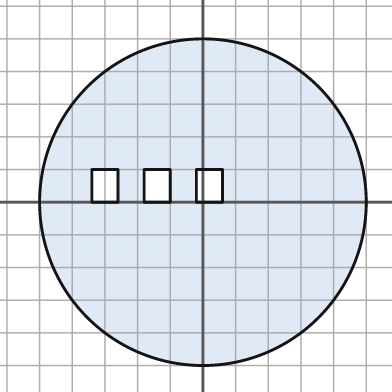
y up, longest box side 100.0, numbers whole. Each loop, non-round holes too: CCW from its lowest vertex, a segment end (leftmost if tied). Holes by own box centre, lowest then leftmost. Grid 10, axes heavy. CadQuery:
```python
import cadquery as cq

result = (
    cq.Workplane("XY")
    .moveTo(0.0, 0.0)
    .circle(50.0)
    .moveTo(-34.0, 0.0)
    .lineTo(-26.0, 0.0)
    .lineTo(-26.0, 10.0)
    .lineTo(-34.0, 10.0)
    .close()
    .moveTo(-18.0, 0.0)
    .lineTo(-10.0, 0.0)
    .lineTo(-10.0, 10.0)
    .lineTo(-18.0, 10.0)
    .close()
    .moveTo(-2.0, 0.0)
    .lineTo(6.0, 0.0)
    .lineTo(6.0, 10.0)
    .lineTo(-2.0, 10.0)
    .close()
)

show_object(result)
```